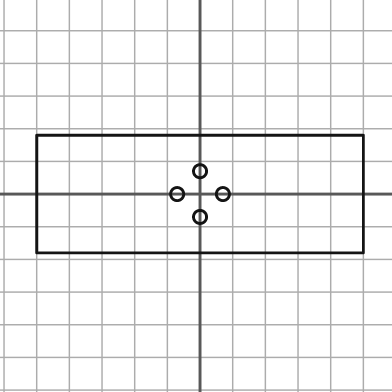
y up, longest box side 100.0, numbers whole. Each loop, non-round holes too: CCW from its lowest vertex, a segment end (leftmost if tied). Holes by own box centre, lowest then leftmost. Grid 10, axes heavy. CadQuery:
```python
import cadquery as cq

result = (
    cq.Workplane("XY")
    .moveTo(-50.0, -18.0)
    .lineTo(50.0, -18.0)
    .lineTo(50.0, 18.0)
    .lineTo(-50.0, 18.0)
    .close()
    .moveTo(0.0, -7.0)
    .circle(2.0)
    .moveTo(-7.0, 0.0)
    .circle(2.0)
    .moveTo(7.0, 0.0)
    .circle(2.0)
    .moveTo(0.0, 7.0)
    .circle(2.0)
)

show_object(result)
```